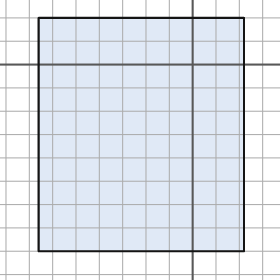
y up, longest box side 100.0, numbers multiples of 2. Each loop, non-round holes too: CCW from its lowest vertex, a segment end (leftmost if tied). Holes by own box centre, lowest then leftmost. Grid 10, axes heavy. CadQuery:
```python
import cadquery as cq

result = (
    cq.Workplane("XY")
    .moveTo(-66.0, -80.0)
    .lineTo(22.0, -80.0)
    .lineTo(22.0, 20.0)
    .lineTo(-66.0, 20.0)
    .close()
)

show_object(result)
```